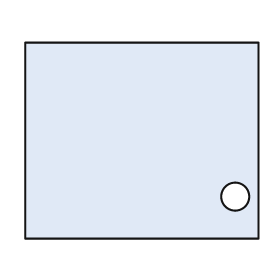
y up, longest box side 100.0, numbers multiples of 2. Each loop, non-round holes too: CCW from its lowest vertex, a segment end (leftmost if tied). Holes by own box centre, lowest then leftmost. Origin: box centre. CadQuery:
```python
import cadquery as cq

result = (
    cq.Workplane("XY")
    .moveTo(-50.0, -42.0)
    .lineTo(50.0, -42.0)
    .lineTo(50.0, 42.0)
    .lineTo(-50.0, 42.0)
    .close()
    .moveTo(40.0, -24.0)
    .circle(6.0)
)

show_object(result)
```